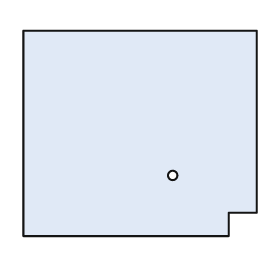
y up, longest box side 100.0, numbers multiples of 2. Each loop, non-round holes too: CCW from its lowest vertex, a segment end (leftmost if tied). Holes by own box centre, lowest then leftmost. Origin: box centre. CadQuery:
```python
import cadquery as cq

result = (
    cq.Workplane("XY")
    .moveTo(-50.0, -44.0)
    .lineTo(38.0, -44.0)
    .lineTo(38.0, -34.0)
    .lineTo(50.0, -34.0)
    .lineTo(50.0, 44.0)
    .lineTo(-50.0, 44.0)
    .close()
    .moveTo(14.0, -18.0)
    .circle(2.0)
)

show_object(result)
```